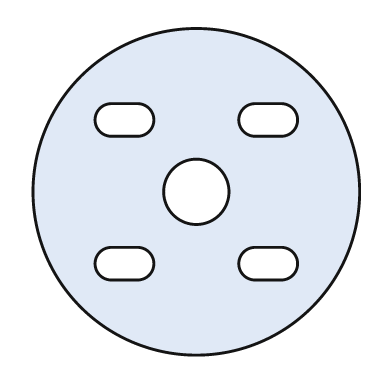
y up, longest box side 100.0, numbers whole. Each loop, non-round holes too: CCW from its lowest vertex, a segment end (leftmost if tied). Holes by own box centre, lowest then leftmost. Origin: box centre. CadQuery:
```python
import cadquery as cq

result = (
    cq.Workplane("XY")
    .moveTo(0.0, 0.0)
    .circle(50.0)
    .moveTo(-26.0, -27.0)
    .lineTo(-18.0, -27.0)
    .threePointArc((-13.0, -22.0), (-18.0, -17.0))
    .lineTo(-26.0, -17.0)
    .threePointArc((-31.0, -22.0), (-26.0, -27.0))
    .close()
    .moveTo(18.0, -27.0)
    .lineTo(26.0, -27.0)
    .threePointArc((31.0, -22.0), (26.0, -17.0))
    .lineTo(18.0, -17.0)
    .threePointArc((13.0, -22.0), (18.0, -27.0))
    .close()
    .moveTo(0.0, 0.0)
    .circle(10.0)
    .moveTo(-26.0, 17.0)
    .lineTo(-18.0, 17.0)
    .threePointArc((-13.0, 22.0), (-18.0, 27.0))
    .lineTo(-26.0, 27.0)
    .threePointArc((-31.0, 22.0), (-26.0, 17.0))
    .close()
    .moveTo(18.0, 17.0)
    .lineTo(26.0, 17.0)
    .threePointArc((31.0, 22.0), (26.0, 27.0))
    .lineTo(18.0, 27.0)
    .threePointArc((13.0, 22.0), (18.0, 17.0))
    .close()
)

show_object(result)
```